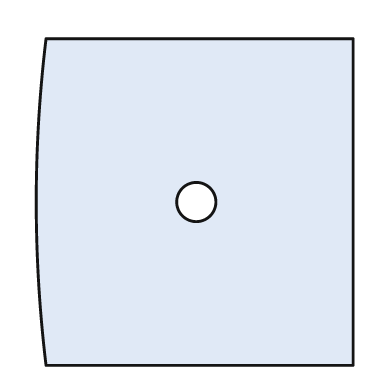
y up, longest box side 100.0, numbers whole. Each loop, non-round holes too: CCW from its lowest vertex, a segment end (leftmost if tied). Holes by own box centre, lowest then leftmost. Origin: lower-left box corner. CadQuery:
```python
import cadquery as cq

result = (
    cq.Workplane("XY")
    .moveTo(3.0, 0.0)
    .lineTo(97.0, 0.0)
    .lineTo(97.0, 100.0)
    .lineTo(3.0, 100.0)
    .threePointArc((0.0, 50.0), (3.0, 0.0))
    .close()
    .moveTo(49.0, 50.0)
    .circle(6.0)
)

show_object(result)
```